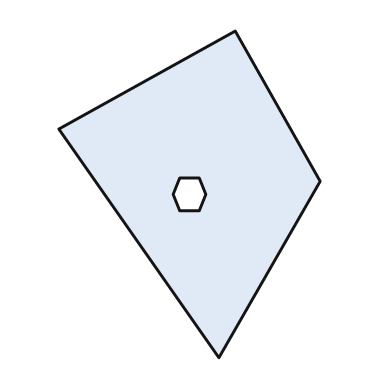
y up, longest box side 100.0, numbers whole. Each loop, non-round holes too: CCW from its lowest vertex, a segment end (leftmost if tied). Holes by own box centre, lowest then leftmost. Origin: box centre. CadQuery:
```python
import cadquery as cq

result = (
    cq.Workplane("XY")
    .moveTo(9.0, -50.0)
    .lineTo(40.0, 4.0)
    .lineTo(14.0, 50.0)
    .lineTo(-40.0, 20.0)
    .close()
    .moveTo(-3.0, -5.0)
    .lineTo(3.0, -5.0)
    .lineTo(5.0, 0.0)
    .lineTo(3.0, 5.0)
    .lineTo(-3.0, 5.0)
    .lineTo(-5.0, 0.0)
    .close()
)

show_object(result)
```